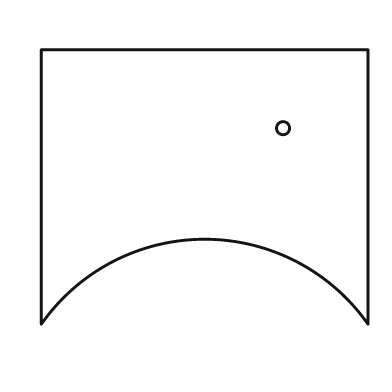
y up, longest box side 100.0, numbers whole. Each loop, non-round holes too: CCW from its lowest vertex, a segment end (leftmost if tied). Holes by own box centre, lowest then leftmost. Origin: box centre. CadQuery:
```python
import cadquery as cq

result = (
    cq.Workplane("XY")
    .moveTo(-50.0, -42.0)
    .threePointArc((0.0, -16.0), (50.0, -42.0))
    .lineTo(50.0, 42.0)
    .lineTo(-50.0, 42.0)
    .close()
    .moveTo(24.0, 18.0)
    .circle(2.0)
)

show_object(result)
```